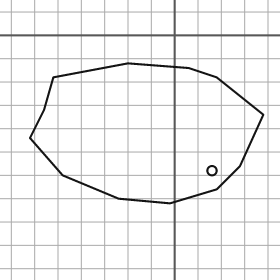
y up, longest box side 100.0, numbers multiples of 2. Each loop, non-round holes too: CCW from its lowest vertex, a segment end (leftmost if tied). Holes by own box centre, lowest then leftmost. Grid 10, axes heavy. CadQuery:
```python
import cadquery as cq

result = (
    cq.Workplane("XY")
    .moveTo(-2.0, -72.0)
    .lineTo(18.0, -66.0)
    .lineTo(28.0, -56.0)
    .lineTo(38.0, -34.0)
    .lineTo(18.0, -18.0)
    .lineTo(6.0, -14.0)
    .lineTo(-20.0, -12.0)
    .lineTo(-52.0, -18.0)
    .lineTo(-56.0, -32.0)
    .lineTo(-62.0, -44.0)
    .lineTo(-48.0, -60.0)
    .lineTo(-24.0, -70.0)
    .close()
    .moveTo(16.0, -58.0)
    .circle(2.0)
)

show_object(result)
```